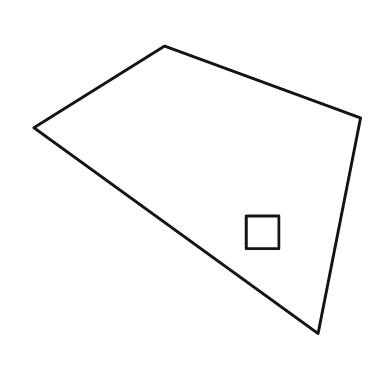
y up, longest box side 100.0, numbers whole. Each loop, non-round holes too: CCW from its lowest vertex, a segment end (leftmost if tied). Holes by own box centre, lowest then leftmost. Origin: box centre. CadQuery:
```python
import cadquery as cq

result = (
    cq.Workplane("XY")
    .moveTo(37.0, -44.0)
    .lineTo(50.0, 22.0)
    .lineTo(-10.0, 44.0)
    .lineTo(-50.0, 19.0)
    .close()
    .moveTo(15.0, -18.0)
    .lineTo(25.0, -18.0)
    .lineTo(25.0, -8.0)
    .lineTo(15.0, -8.0)
    .close()
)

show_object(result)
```